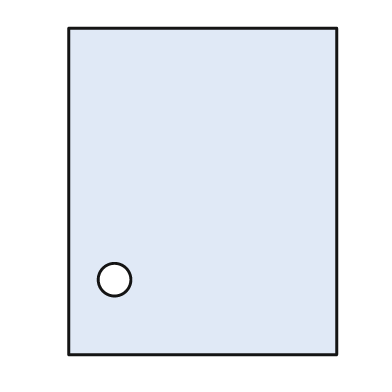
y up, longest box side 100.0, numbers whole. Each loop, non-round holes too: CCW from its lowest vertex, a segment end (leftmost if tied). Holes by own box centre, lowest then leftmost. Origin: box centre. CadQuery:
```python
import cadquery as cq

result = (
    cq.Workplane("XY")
    .moveTo(-41.0, -50.0)
    .lineTo(41.0, -50.0)
    .lineTo(41.0, 50.0)
    .lineTo(-41.0, 50.0)
    .close()
    .moveTo(-27.0, -27.0)
    .circle(5.0)
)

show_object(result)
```